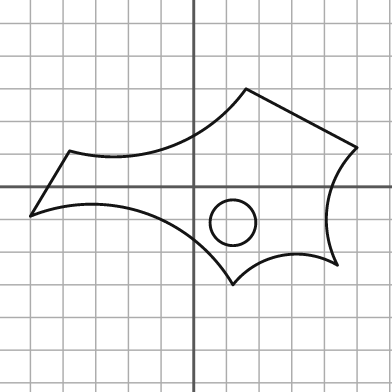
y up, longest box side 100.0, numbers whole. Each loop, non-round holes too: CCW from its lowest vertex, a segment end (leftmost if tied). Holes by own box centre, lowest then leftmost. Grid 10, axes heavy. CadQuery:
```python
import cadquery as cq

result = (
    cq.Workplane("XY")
    .moveTo(12.0, -30.0)
    .threePointArc((27.0, -21.0), (44.0, -24.0))
    .threePointArc((41.0, -5.0), (50.0, 12.0))
    .lineTo(16.0, 30.0)
    .threePointArc((-8.0, 12.0), (-38.0, 11.0))
    .lineTo(-50.0, -9.0)
    .threePointArc((-15.0, -8.0), (12.0, -30.0))
    .close()
    .moveTo(12.0, -11.0)
    .circle(7.0)
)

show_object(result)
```